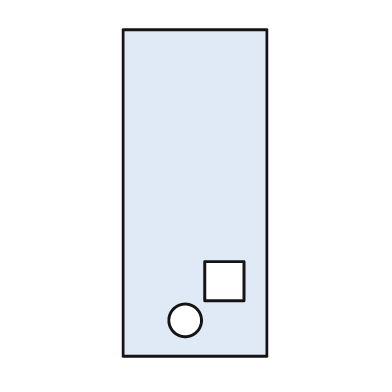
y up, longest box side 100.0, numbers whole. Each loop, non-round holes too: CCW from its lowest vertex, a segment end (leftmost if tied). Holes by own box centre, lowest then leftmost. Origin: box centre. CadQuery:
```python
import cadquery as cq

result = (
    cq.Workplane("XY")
    .moveTo(-22.0, -50.0)
    .lineTo(22.0, -50.0)
    .lineTo(22.0, 50.0)
    .lineTo(-22.0, 50.0)
    .close()
    .moveTo(-3.0, -39.0)
    .circle(5.0)
    .moveTo(3.0, -33.0)
    .lineTo(15.0, -33.0)
    .lineTo(15.0, -21.0)
    .lineTo(3.0, -21.0)
    .close()
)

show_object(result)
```